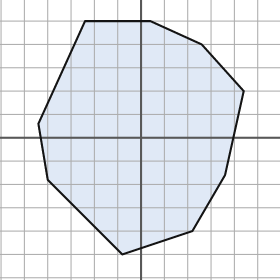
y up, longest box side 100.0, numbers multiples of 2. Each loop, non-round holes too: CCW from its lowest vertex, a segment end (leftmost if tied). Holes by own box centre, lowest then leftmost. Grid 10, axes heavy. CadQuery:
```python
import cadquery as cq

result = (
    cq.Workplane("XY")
    .moveTo(-8.0, -50.0)
    .lineTo(22.0, -40.0)
    .lineTo(36.0, -16.0)
    .lineTo(44.0, 20.0)
    .lineTo(26.0, 40.0)
    .lineTo(4.0, 50.0)
    .lineTo(-24.0, 50.0)
    .lineTo(-44.0, 6.0)
    .lineTo(-40.0, -18.0)
    .close()
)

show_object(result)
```